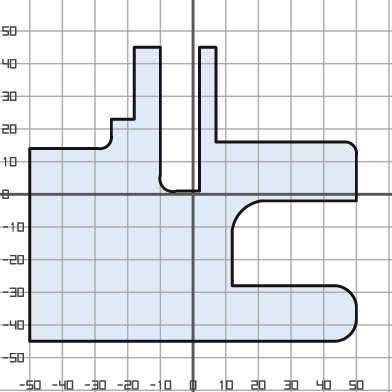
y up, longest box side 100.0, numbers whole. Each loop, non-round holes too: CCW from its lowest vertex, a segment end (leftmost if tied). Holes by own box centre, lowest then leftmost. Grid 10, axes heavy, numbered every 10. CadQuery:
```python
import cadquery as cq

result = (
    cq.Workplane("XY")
    .moveTo(-50.0, -45.0)
    .lineTo(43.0, -45.0)
    .threePointArc((48.0, -43.0), (50.0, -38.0))
    .lineTo(50.0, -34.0)
    .threePointArc((48.0, -30.0), (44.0, -28.0))
    .lineTo(12.0, -28.0)
    .lineTo(12.0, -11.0)
    .threePointArc((15.0, -5.0), (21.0, -2.0))
    .lineTo(50.0, -2.0)
    .lineTo(50.0, 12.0)
    .threePointArc((49.0, 15.0), (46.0, 16.0))
    .lineTo(7.0, 16.0)
    .lineTo(7.0, 45.0)
    .lineTo(2.0, 45.0)
    .lineTo(2.0, 1.0)
    .lineTo(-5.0, 1.0)
    .threePointArc((-9.0, 2.0), (-10.0, 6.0))
    .lineTo(-10.0, 45.0)
    .lineTo(-18.0, 45.0)
    .lineTo(-18.0, 23.0)
    .lineTo(-25.0, 23.0)
    .lineTo(-25.0, 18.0)
    .threePointArc((-26.0, 15.0), (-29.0, 14.0))
    .lineTo(-50.0, 14.0)
    .close()
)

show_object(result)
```